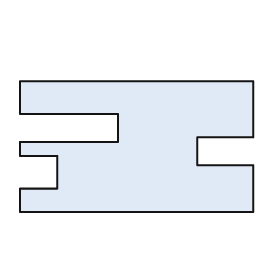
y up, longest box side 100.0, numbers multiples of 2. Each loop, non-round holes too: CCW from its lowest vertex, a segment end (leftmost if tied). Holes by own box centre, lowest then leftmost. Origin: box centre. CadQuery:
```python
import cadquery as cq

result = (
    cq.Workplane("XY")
    .moveTo(-50.0, -28.0)
    .lineTo(50.0, -28.0)
    .lineTo(50.0, -8.0)
    .lineTo(26.0, -8.0)
    .lineTo(26.0, 4.0)
    .lineTo(50.0, 4.0)
    .lineTo(50.0, 28.0)
    .lineTo(-50.0, 28.0)
    .lineTo(-50.0, 14.0)
    .lineTo(-8.0, 14.0)
    .lineTo(-8.0, 2.0)
    .lineTo(-50.0, 2.0)
    .lineTo(-50.0, -4.0)
    .lineTo(-34.0, -4.0)
    .lineTo(-34.0, -18.0)
    .lineTo(-50.0, -18.0)
    .close()
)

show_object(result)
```